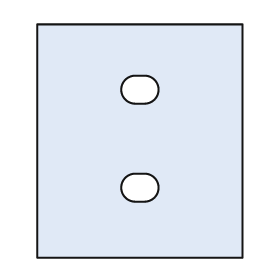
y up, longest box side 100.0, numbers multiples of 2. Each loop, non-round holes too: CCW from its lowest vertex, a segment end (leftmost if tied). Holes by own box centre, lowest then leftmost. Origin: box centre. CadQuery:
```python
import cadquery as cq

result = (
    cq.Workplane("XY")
    .moveTo(-44.0, -50.0)
    .lineTo(44.0, -50.0)
    .lineTo(44.0, 50.0)
    .lineTo(-44.0, 50.0)
    .close()
    .moveTo(-2.0, -26.0)
    .lineTo(2.0, -26.0)
    .threePointArc((8.0, -20.0), (2.0, -14.0))
    .lineTo(-2.0, -14.0)
    .threePointArc((-8.0, -20.0), (-2.0, -26.0))
    .close()
    .moveTo(-2.0, 16.0)
    .lineTo(2.0, 16.0)
    .threePointArc((8.0, 22.0), (2.0, 28.0))
    .lineTo(-2.0, 28.0)
    .threePointArc((-8.0, 22.0), (-2.0, 16.0))
    .close()
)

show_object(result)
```